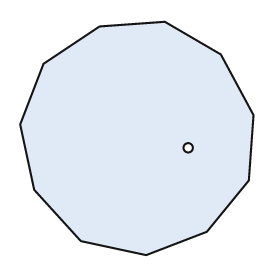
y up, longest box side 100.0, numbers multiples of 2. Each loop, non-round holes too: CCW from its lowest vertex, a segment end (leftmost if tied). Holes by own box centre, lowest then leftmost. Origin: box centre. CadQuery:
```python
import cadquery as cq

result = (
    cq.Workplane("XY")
    .moveTo(4.0, -50.0)
    .lineTo(30.0, -40.0)
    .lineTo(48.0, -18.0)
    .lineTo(50.0, 10.0)
    .lineTo(36.0, 36.0)
    .lineTo(12.0, 50.0)
    .lineTo(-16.0, 48.0)
    .lineTo(-40.0, 32.0)
    .lineTo(-50.0, 6.0)
    .lineTo(-44.0, -22.0)
    .lineTo(-24.0, -44.0)
    .close()
    .moveTo(22.0, -4.0)
    .circle(2.0)
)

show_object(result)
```